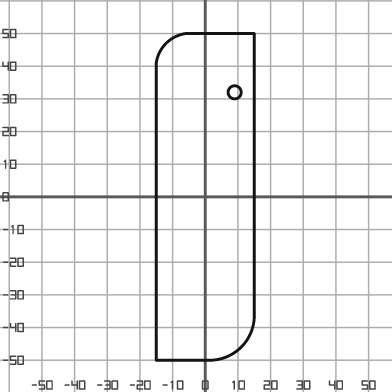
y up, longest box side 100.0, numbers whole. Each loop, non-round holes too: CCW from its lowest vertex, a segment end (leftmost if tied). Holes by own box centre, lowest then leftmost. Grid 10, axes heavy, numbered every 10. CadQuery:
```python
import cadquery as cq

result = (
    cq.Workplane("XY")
    .moveTo(-15.0, -50.0)
    .lineTo(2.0, -50.0)
    .threePointArc((11.0, -46.0), (15.0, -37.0))
    .lineTo(15.0, 50.0)
    .lineTo(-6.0, 50.0)
    .threePointArc((-12.0, 47.0), (-15.0, 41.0))
    .close()
    .moveTo(9.0, 32.0)
    .circle(2.0)
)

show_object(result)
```